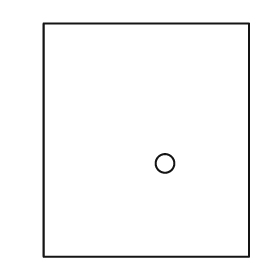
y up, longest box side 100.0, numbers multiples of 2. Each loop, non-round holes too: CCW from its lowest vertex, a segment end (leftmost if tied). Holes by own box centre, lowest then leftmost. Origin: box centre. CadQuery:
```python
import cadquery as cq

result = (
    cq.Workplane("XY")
    .moveTo(-44.0, -50.0)
    .lineTo(44.0, -50.0)
    .lineTo(44.0, 50.0)
    .lineTo(-44.0, 50.0)
    .close()
    .moveTo(8.0, -10.0)
    .circle(4.0)
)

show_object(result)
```